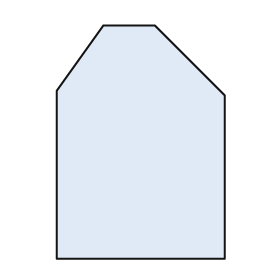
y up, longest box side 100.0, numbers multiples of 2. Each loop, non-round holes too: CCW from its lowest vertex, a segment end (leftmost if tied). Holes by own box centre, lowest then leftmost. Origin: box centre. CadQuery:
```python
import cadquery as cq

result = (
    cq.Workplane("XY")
    .moveTo(-36.0, -50.0)
    .lineTo(36.0, -50.0)
    .lineTo(36.0, 20.0)
    .lineTo(6.0, 50.0)
    .lineTo(-16.0, 50.0)
    .lineTo(-36.0, 22.0)
    .close()
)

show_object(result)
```